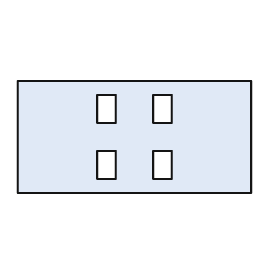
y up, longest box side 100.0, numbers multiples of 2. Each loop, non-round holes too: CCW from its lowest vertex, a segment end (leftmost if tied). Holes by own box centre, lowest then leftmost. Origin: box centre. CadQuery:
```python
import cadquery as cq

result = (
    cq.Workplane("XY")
    .moveTo(-50.0, -24.0)
    .lineTo(50.0, -24.0)
    .lineTo(50.0, 24.0)
    .lineTo(-50.0, 24.0)
    .close()
    .moveTo(-16.0, -18.0)
    .lineTo(-8.0, -18.0)
    .lineTo(-8.0, -6.0)
    .lineTo(-16.0, -6.0)
    .close()
    .moveTo(8.0, -18.0)
    .lineTo(16.0, -18.0)
    .lineTo(16.0, -6.0)
    .lineTo(8.0, -6.0)
    .close()
    .moveTo(-16.0, 6.0)
    .lineTo(-8.0, 6.0)
    .lineTo(-8.0, 18.0)
    .lineTo(-16.0, 18.0)
    .close()
    .moveTo(8.0, 6.0)
    .lineTo(16.0, 6.0)
    .lineTo(16.0, 18.0)
    .lineTo(8.0, 18.0)
    .close()
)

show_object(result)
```